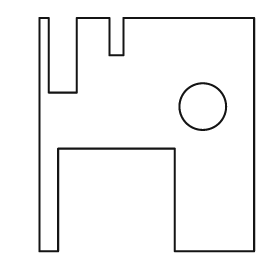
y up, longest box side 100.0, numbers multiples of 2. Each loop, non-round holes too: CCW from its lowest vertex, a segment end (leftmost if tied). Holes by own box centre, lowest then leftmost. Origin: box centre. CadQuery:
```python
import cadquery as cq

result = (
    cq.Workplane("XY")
    .moveTo(-46.0, -50.0)
    .lineTo(-38.0, -50.0)
    .lineTo(-38.0, -6.0)
    .lineTo(12.0, -6.0)
    .lineTo(12.0, -50.0)
    .lineTo(46.0, -50.0)
    .lineTo(46.0, 50.0)
    .lineTo(-10.0, 50.0)
    .lineTo(-10.0, 34.0)
    .lineTo(-16.0, 34.0)
    .lineTo(-16.0, 50.0)
    .lineTo(-30.0, 50.0)
    .lineTo(-30.0, 18.0)
    .lineTo(-42.0, 18.0)
    .lineTo(-42.0, 50.0)
    .lineTo(-46.0, 50.0)
    .close()
    .moveTo(24.0, 12.0)
    .circle(10.0)
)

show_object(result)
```